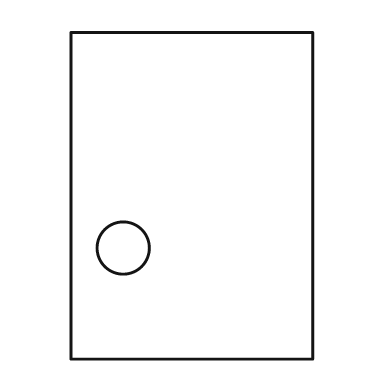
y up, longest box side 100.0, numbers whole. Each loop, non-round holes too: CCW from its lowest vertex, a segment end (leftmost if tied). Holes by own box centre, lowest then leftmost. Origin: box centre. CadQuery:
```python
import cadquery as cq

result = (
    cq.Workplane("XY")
    .moveTo(-37.0, -50.0)
    .lineTo(37.0, -50.0)
    .lineTo(37.0, 50.0)
    .lineTo(-37.0, 50.0)
    .close()
    .moveTo(-21.0, -16.0)
    .circle(8.0)
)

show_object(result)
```